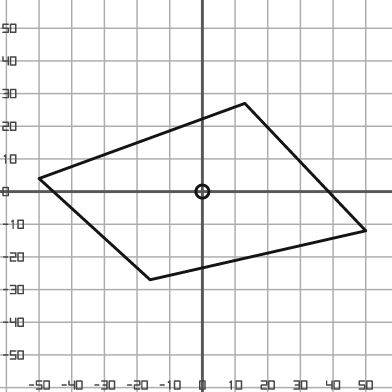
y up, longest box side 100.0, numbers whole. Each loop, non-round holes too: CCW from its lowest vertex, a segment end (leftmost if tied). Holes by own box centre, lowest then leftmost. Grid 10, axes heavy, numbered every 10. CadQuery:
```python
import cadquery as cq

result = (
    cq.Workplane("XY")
    .moveTo(-16.0, -27.0)
    .lineTo(50.0, -12.0)
    .lineTo(13.0, 27.0)
    .lineTo(-50.0, 4.0)
    .close()
    .moveTo(0.0, 0.0)
    .circle(2.0)
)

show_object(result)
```